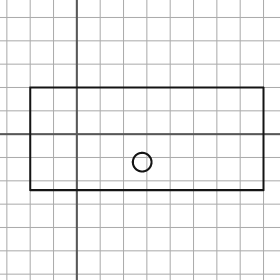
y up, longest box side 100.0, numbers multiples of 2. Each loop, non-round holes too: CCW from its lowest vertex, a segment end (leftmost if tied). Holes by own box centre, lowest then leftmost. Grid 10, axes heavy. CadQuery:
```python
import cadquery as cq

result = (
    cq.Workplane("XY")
    .moveTo(-20.0, -24.0)
    .lineTo(80.0, -24.0)
    .lineTo(80.0, 20.0)
    .lineTo(-20.0, 20.0)
    .close()
    .moveTo(28.0, -12.0)
    .circle(4.0)
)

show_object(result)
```